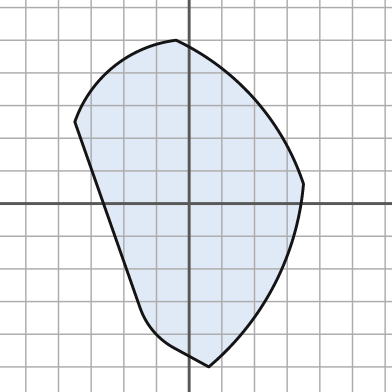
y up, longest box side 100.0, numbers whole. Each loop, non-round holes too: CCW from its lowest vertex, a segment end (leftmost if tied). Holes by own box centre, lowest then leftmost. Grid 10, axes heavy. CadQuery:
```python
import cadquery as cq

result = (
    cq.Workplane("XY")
    .moveTo(6.0, -50.0)
    .threePointArc((26.0, -25.0), (35.0, 6.0))
    .threePointArc((20.0, 32.0), (-4.0, 50.0))
    .threePointArc((-23.0, 42.0), (-35.0, 25.0))
    .lineTo(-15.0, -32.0)
    .threePointArc((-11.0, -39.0), (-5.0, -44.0))
    .close()
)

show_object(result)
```